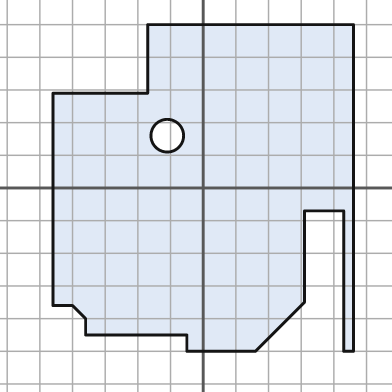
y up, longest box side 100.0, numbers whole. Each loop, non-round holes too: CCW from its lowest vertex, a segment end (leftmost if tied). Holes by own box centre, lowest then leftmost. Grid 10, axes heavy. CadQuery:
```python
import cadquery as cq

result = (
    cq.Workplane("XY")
    .moveTo(-5.0, -50.0)
    .lineTo(16.0, -50.0)
    .lineTo(31.0, -35.0)
    .lineTo(31.0, -7.0)
    .lineTo(43.0, -7.0)
    .lineTo(43.0, -50.0)
    .lineTo(46.0, -50.0)
    .lineTo(46.0, 50.0)
    .lineTo(-17.0, 50.0)
    .lineTo(-17.0, 29.0)
    .lineTo(-46.0, 29.0)
    .lineTo(-46.0, -36.0)
    .lineTo(-40.0, -36.0)
    .lineTo(-36.0, -40.0)
    .lineTo(-36.0, -45.0)
    .lineTo(-5.0, -45.0)
    .close()
    .moveTo(-11.0, 16.0)
    .circle(5.0)
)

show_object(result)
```